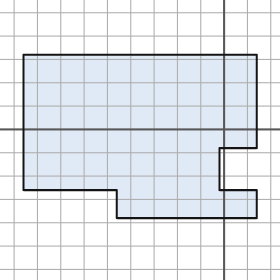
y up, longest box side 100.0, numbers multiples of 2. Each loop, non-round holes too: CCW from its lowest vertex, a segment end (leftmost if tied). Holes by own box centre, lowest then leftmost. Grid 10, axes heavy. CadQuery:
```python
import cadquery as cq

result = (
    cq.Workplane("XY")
    .moveTo(-46.0, -38.0)
    .lineTo(14.0, -38.0)
    .lineTo(14.0, -26.0)
    .lineTo(-2.0, -26.0)
    .lineTo(-2.0, -8.0)
    .lineTo(14.0, -8.0)
    .lineTo(14.0, 32.0)
    .lineTo(-86.0, 32.0)
    .lineTo(-86.0, -26.0)
    .lineTo(-46.0, -26.0)
    .close()
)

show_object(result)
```